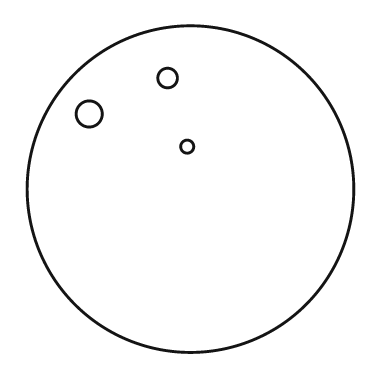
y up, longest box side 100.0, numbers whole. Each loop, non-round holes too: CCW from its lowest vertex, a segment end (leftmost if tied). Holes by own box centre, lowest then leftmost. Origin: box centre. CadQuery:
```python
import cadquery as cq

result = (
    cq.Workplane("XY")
    .moveTo(0.0, 0.0)
    .circle(50.0)
    .moveTo(-1.0, 13.0)
    .circle(2.0)
    .moveTo(-31.0, 23.0)
    .circle(4.0)
    .moveTo(-7.0, 34.0)
    .circle(3.0)
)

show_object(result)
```